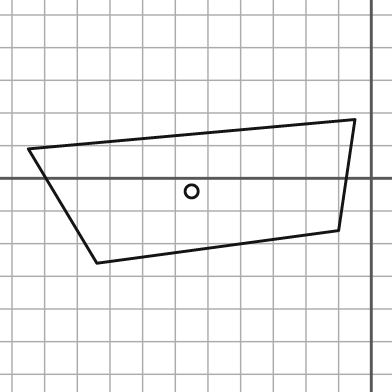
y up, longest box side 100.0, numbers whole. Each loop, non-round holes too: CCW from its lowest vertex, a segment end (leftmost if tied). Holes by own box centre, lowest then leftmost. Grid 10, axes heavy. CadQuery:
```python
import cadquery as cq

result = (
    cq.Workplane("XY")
    .moveTo(-84.0, -26.0)
    .lineTo(-10.0, -16.0)
    .lineTo(-5.0, 18.0)
    .lineTo(-105.0, 9.0)
    .close()
    .moveTo(-55.0, -4.0)
    .circle(2.0)
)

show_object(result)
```